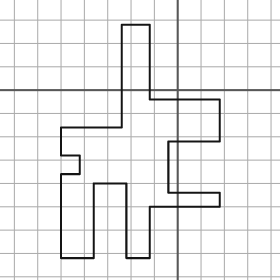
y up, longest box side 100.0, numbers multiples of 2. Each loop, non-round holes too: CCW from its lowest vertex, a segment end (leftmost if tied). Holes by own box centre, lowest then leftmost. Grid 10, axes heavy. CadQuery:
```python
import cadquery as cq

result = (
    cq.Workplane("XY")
    .moveTo(-50.0, -72.0)
    .lineTo(-36.0, -72.0)
    .lineTo(-36.0, -40.0)
    .lineTo(-22.0, -40.0)
    .lineTo(-22.0, -72.0)
    .lineTo(-12.0, -72.0)
    .lineTo(-12.0, -50.0)
    .lineTo(18.0, -50.0)
    .lineTo(18.0, -44.0)
    .lineTo(-4.0, -44.0)
    .lineTo(-4.0, -22.0)
    .lineTo(18.0, -22.0)
    .lineTo(18.0, -4.0)
    .lineTo(-12.0, -4.0)
    .lineTo(-12.0, 28.0)
    .lineTo(-24.0, 28.0)
    .lineTo(-24.0, -16.0)
    .lineTo(-50.0, -16.0)
    .lineTo(-50.0, -28.0)
    .lineTo(-42.0, -28.0)
    .lineTo(-42.0, -36.0)
    .lineTo(-50.0, -36.0)
    .close()
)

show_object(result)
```